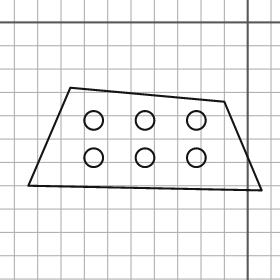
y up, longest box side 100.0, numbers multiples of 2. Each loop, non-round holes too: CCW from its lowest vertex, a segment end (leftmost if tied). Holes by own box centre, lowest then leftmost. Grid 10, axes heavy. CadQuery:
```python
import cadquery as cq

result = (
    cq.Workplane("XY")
    .moveTo(6.0, -72.0)
    .lineTo(-10.0, -34.0)
    .lineTo(-76.0, -28.0)
    .lineTo(-94.0, -70.0)
    .close()
    .moveTo(-66.0, -58.0)
    .circle(4.0)
    .moveTo(-44.0, -58.0)
    .circle(4.0)
    .moveTo(-22.0, -58.0)
    .circle(4.0)
    .moveTo(-66.0, -42.0)
    .circle(4.0)
    .moveTo(-44.0, -42.0)
    .circle(4.0)
    .moveTo(-22.0, -42.0)
    .circle(4.0)
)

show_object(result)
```